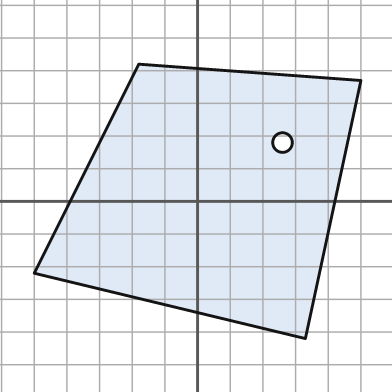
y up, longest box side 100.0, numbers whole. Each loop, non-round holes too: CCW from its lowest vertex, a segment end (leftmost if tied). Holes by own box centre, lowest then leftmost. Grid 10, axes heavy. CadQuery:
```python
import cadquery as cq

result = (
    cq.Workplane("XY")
    .moveTo(33.0, -42.0)
    .lineTo(50.0, 37.0)
    .lineTo(-18.0, 42.0)
    .lineTo(-50.0, -22.0)
    .close()
    .moveTo(26.0, 18.0)
    .circle(3.0)
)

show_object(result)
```